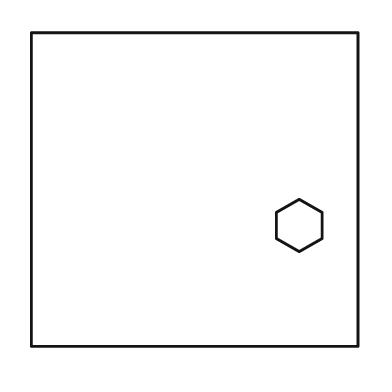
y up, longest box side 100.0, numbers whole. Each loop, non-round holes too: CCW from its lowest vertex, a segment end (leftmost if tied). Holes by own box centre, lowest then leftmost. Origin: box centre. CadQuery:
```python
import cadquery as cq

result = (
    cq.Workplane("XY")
    .moveTo(-50.0, -48.0)
    .lineTo(50.0, -48.0)
    .lineTo(50.0, 48.0)
    .lineTo(-50.0, 48.0)
    .close()
    .moveTo(32.0, -19.0)
    .lineTo(39.0, -15.0)
    .lineTo(39.0, -7.0)
    .lineTo(32.0, -3.0)
    .lineTo(25.0, -7.0)
    .lineTo(25.0, -15.0)
    .close()
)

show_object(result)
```